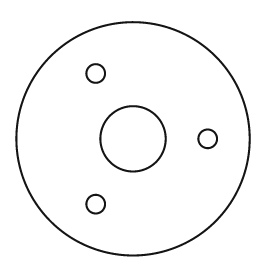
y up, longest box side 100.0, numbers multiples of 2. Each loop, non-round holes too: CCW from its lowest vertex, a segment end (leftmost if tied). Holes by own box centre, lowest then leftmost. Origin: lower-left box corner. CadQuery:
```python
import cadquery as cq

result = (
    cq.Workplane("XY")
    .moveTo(50.0, 50.0)
    .circle(50.0)
    .moveTo(34.0, 22.0)
    .circle(4.0)
    .moveTo(50.0, 50.0)
    .circle(14.0)
    .moveTo(82.0, 50.0)
    .circle(4.0)
    .moveTo(34.0, 78.0)
    .circle(4.0)
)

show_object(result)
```